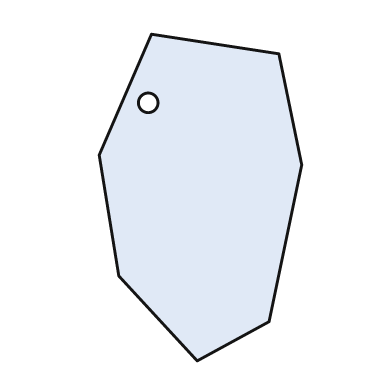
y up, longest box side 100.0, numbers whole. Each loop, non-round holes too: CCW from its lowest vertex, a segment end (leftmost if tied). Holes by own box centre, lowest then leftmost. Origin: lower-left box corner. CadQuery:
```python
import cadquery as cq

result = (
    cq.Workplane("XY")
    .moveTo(30.0, 0.0)
    .lineTo(52.0, 12.0)
    .lineTo(62.0, 60.0)
    .lineTo(55.0, 94.0)
    .lineTo(16.0, 100.0)
    .lineTo(0.0, 63.0)
    .lineTo(6.0, 26.0)
    .close()
    .moveTo(15.0, 79.0)
    .circle(3.0)
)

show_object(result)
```